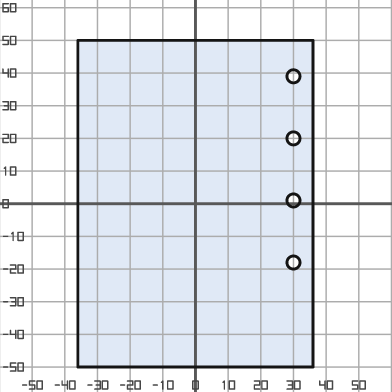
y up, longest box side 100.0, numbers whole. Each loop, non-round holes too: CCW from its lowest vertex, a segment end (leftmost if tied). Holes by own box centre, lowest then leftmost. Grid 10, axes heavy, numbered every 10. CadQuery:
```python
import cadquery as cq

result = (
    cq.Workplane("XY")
    .moveTo(-36.0, -50.0)
    .lineTo(36.0, -50.0)
    .lineTo(36.0, 50.0)
    .lineTo(-36.0, 50.0)
    .close()
    .moveTo(30.0, -18.0)
    .circle(2.0)
    .moveTo(30.0, 1.0)
    .circle(2.0)
    .moveTo(30.0, 20.0)
    .circle(2.0)
    .moveTo(30.0, 39.0)
    .circle(2.0)
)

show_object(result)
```